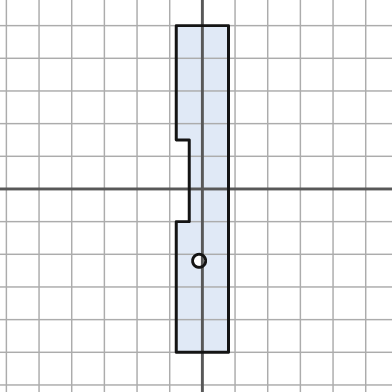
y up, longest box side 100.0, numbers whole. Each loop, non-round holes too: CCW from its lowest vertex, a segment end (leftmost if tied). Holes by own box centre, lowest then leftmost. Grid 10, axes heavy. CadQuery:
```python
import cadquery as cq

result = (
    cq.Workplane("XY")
    .moveTo(-8.0, -50.0)
    .lineTo(8.0, -50.0)
    .lineTo(8.0, 50.0)
    .lineTo(-8.0, 50.0)
    .lineTo(-8.0, 15.0)
    .lineTo(-4.0, 15.0)
    .lineTo(-4.0, -10.0)
    .lineTo(-8.0, -10.0)
    .close()
    .moveTo(-1.0, -22.0)
    .circle(2.0)
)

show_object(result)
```